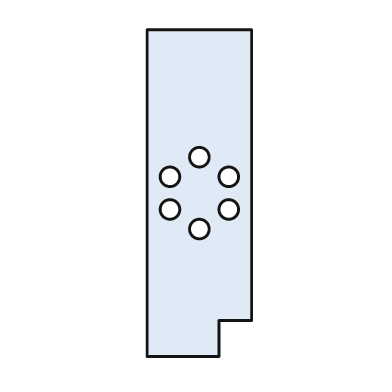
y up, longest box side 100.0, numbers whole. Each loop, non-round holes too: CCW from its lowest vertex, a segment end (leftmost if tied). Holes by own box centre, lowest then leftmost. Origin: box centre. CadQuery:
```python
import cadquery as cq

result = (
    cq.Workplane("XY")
    .moveTo(-16.0, -50.0)
    .lineTo(6.0, -50.0)
    .lineTo(6.0, -39.0)
    .lineTo(16.0, -39.0)
    .lineTo(16.0, 50.0)
    .lineTo(-16.0, 50.0)
    .close()
    .moveTo(0.0, -11.0)
    .circle(3.0)
    .moveTo(-9.0, -5.0)
    .circle(3.0)
    .moveTo(9.0, -5.0)
    .circle(3.0)
    .moveTo(-9.0, 5.0)
    .circle(3.0)
    .moveTo(9.0, 5.0)
    .circle(3.0)
    .moveTo(0.0, 11.0)
    .circle(3.0)
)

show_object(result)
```